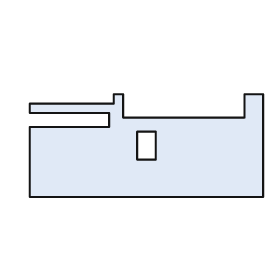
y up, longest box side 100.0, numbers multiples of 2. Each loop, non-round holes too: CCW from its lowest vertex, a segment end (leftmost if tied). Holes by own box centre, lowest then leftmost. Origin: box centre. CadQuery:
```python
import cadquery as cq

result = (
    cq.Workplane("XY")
    .moveTo(-50.0, -22.0)
    .lineTo(50.0, -22.0)
    .lineTo(50.0, 22.0)
    .lineTo(42.0, 22.0)
    .lineTo(42.0, 12.0)
    .lineTo(-10.0, 12.0)
    .lineTo(-10.0, 22.0)
    .lineTo(-14.0, 22.0)
    .lineTo(-14.0, 18.0)
    .lineTo(-50.0, 18.0)
    .lineTo(-50.0, 14.0)
    .lineTo(-16.0, 14.0)
    .lineTo(-16.0, 8.0)
    .lineTo(-50.0, 8.0)
    .close()
    .moveTo(-4.0, -6.0)
    .lineTo(4.0, -6.0)
    .lineTo(4.0, 6.0)
    .lineTo(-4.0, 6.0)
    .close()
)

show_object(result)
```